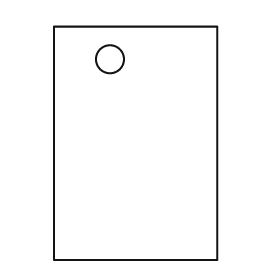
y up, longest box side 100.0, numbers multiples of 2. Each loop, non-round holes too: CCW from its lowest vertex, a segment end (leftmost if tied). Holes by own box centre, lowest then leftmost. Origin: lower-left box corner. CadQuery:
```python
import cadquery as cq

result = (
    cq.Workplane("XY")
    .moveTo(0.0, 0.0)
    .lineTo(70.0, 0.0)
    .lineTo(70.0, 100.0)
    .lineTo(0.0, 100.0)
    .close()
    .moveTo(24.0, 86.0)
    .circle(6.0)
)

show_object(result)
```